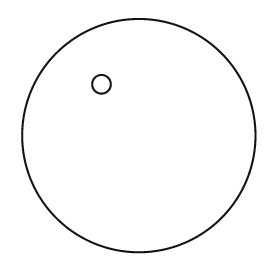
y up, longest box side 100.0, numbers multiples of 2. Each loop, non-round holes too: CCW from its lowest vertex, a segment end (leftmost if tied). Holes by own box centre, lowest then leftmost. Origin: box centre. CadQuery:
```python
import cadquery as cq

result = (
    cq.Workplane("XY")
    .moveTo(0.0, 0.0)
    .circle(50.0)
    .moveTo(-16.0, 22.0)
    .circle(4.0)
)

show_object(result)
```